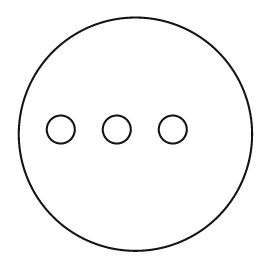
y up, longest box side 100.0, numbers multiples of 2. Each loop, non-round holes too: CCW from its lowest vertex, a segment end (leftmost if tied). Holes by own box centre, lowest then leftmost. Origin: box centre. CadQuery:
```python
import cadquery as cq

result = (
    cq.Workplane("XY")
    .moveTo(0.0, 0.0)
    .circle(50.0)
    .moveTo(-32.0, 2.0)
    .circle(6.0)
    .moveTo(-8.0, 2.0)
    .circle(6.0)
    .moveTo(16.0, 2.0)
    .circle(6.0)
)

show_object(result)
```